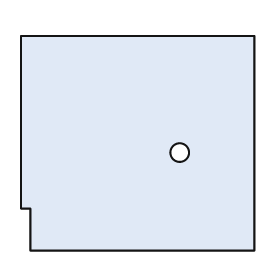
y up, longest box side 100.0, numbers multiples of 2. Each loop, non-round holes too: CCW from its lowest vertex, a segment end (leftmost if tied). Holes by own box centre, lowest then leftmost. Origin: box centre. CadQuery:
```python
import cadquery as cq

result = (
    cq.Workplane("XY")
    .moveTo(-46.0, -46.0)
    .lineTo(50.0, -46.0)
    .lineTo(50.0, 46.0)
    .lineTo(-50.0, 46.0)
    .lineTo(-50.0, -28.0)
    .lineTo(-46.0, -28.0)
    .close()
    .moveTo(18.0, -4.0)
    .circle(4.0)
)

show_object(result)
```